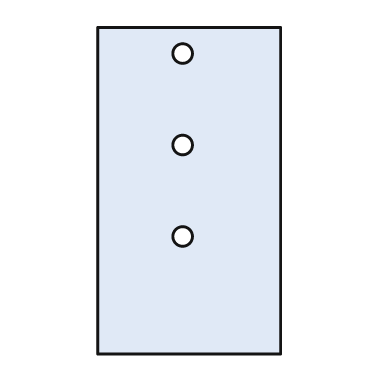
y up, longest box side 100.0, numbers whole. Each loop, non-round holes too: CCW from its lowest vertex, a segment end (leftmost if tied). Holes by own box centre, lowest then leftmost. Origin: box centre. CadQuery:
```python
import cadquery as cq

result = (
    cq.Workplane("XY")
    .moveTo(-28.0, -50.0)
    .lineTo(28.0, -50.0)
    .lineTo(28.0, 50.0)
    .lineTo(-28.0, 50.0)
    .close()
    .moveTo(-2.0, -14.0)
    .circle(3.0)
    .moveTo(-2.0, 14.0)
    .circle(3.0)
    .moveTo(-2.0, 42.0)
    .circle(3.0)
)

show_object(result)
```